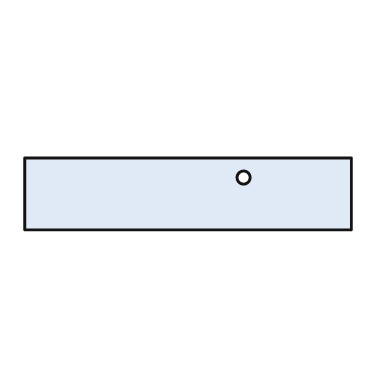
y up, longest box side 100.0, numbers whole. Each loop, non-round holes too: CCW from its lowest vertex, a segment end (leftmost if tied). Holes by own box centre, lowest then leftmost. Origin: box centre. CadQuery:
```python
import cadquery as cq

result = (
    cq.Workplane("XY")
    .moveTo(-50.0, -11.0)
    .lineTo(50.0, -11.0)
    .lineTo(50.0, 11.0)
    .lineTo(-50.0, 11.0)
    .close()
    .moveTo(17.0, 5.0)
    .circle(2.0)
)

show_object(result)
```